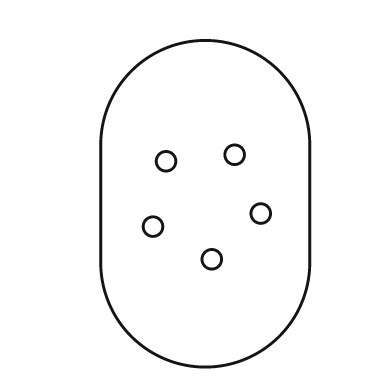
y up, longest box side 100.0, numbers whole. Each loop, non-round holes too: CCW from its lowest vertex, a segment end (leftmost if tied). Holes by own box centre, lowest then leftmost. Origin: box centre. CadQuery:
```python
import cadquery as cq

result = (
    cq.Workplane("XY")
    .moveTo(-32.0, -18.0)
    .threePointArc((0.0, -50.0), (32.0, -18.0))
    .lineTo(32.0, 18.0)
    .threePointArc((0.0, 50.0), (-32.0, 18.0))
    .close()
    .moveTo(2.0, -17.0)
    .circle(3.0)
    .moveTo(-16.0, -7.0)
    .circle(3.0)
    .moveTo(17.0, -3.0)
    .circle(3.0)
    .moveTo(-12.0, 13.0)
    .circle(3.0)
    .moveTo(9.0, 15.0)
    .circle(3.0)
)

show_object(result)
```